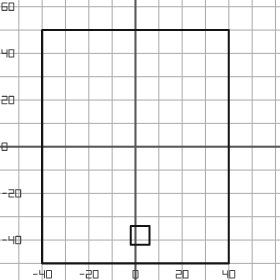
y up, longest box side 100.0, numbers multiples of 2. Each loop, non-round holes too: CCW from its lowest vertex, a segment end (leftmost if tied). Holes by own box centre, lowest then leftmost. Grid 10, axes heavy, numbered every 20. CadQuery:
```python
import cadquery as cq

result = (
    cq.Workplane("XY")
    .moveTo(-40.0, -50.0)
    .lineTo(40.0, -50.0)
    .lineTo(40.0, 50.0)
    .lineTo(-40.0, 50.0)
    .close()
    .moveTo(-2.0, -42.0)
    .lineTo(6.0, -42.0)
    .lineTo(6.0, -34.0)
    .lineTo(-2.0, -34.0)
    .close()
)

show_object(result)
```